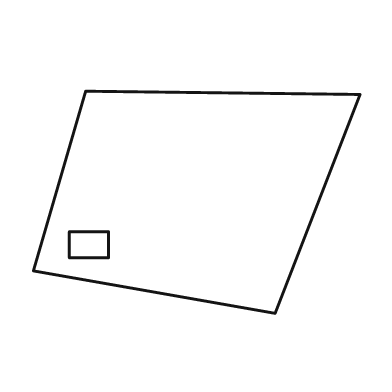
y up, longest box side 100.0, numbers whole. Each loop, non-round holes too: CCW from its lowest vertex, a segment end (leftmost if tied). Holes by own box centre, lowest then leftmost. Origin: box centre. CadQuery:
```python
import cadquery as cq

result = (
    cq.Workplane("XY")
    .moveTo(24.0, -34.0)
    .lineTo(50.0, 33.0)
    .lineTo(-34.0, 34.0)
    .lineTo(-50.0, -21.0)
    .close()
    .moveTo(-39.0, -17.0)
    .lineTo(-27.0, -17.0)
    .lineTo(-27.0, -9.0)
    .lineTo(-39.0, -9.0)
    .close()
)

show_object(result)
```